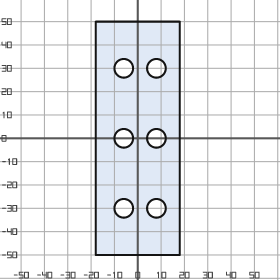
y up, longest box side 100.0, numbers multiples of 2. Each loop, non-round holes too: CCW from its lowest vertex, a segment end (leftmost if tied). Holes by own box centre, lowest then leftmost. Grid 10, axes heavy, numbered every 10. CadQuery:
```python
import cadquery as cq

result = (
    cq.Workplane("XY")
    .moveTo(-18.0, -50.0)
    .lineTo(18.0, -50.0)
    .lineTo(18.0, 50.0)
    .lineTo(-18.0, 50.0)
    .close()
    .moveTo(-6.0, -30.0)
    .circle(4.0)
    .moveTo(8.0, -30.0)
    .circle(4.0)
    .moveTo(-6.0, 0.0)
    .circle(4.0)
    .moveTo(8.0, 0.0)
    .circle(4.0)
    .moveTo(-6.0, 30.0)
    .circle(4.0)
    .moveTo(8.0, 30.0)
    .circle(4.0)
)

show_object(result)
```